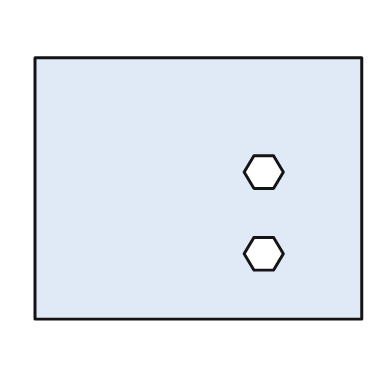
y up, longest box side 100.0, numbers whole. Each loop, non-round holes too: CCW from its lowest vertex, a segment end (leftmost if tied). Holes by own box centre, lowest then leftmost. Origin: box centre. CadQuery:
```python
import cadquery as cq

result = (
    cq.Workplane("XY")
    .moveTo(-50.0, -40.0)
    .lineTo(50.0, -40.0)
    .lineTo(50.0, 40.0)
    .lineTo(-50.0, 40.0)
    .close()
    .moveTo(17.0, -25.0)
    .lineTo(23.0, -25.0)
    .lineTo(26.0, -20.0)
    .lineTo(23.0, -15.0)
    .lineTo(17.0, -15.0)
    .lineTo(14.0, -20.0)
    .close()
    .moveTo(17.0, 0.0)
    .lineTo(23.0, 0.0)
    .lineTo(26.0, 5.0)
    .lineTo(23.0, 10.0)
    .lineTo(17.0, 10.0)
    .lineTo(14.0, 5.0)
    .close()
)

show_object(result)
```